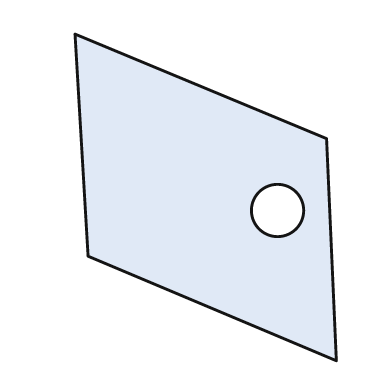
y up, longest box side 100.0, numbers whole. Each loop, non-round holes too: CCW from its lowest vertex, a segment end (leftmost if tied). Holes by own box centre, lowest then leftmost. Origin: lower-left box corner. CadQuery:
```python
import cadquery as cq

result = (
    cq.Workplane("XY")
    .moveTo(80.0, 0.0)
    .lineTo(77.0, 68.0)
    .lineTo(0.0, 100.0)
    .lineTo(4.0, 32.0)
    .close()
    .moveTo(62.0, 46.0)
    .circle(8.0)
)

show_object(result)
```